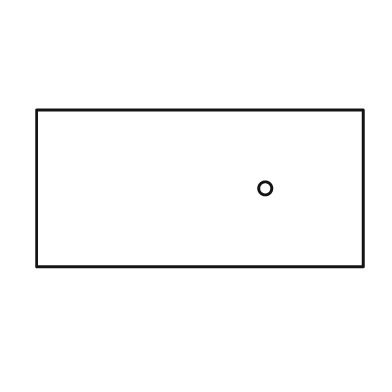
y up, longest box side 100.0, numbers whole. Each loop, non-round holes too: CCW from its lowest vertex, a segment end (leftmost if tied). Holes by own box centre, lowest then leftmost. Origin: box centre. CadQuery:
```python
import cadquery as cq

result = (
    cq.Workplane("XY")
    .moveTo(-50.0, -24.0)
    .lineTo(50.0, -24.0)
    .lineTo(50.0, 24.0)
    .lineTo(-50.0, 24.0)
    .close()
    .moveTo(20.0, 0.0)
    .circle(2.0)
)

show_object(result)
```